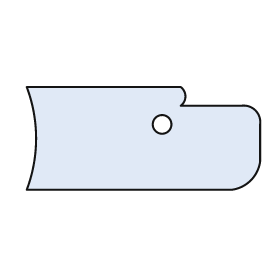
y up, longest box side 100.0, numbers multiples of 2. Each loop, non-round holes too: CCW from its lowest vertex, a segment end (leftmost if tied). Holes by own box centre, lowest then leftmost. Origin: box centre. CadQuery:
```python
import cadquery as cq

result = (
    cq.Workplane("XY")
    .moveTo(-50.0, -22.0)
    .lineTo(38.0, -22.0)
    .threePointArc((46.0, -18.0), (50.0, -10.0))
    .lineTo(50.0, 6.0)
    .threePointArc((48.0, 12.0), (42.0, 14.0))
    .lineTo(16.0, 14.0)
    .threePointArc((18.0, 18.0), (16.0, 22.0))
    .lineTo(-50.0, 22.0)
    .threePointArc((-46.0, 0.0), (-50.0, -22.0))
    .close()
    .moveTo(8.0, 6.0)
    .circle(4.0)
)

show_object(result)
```